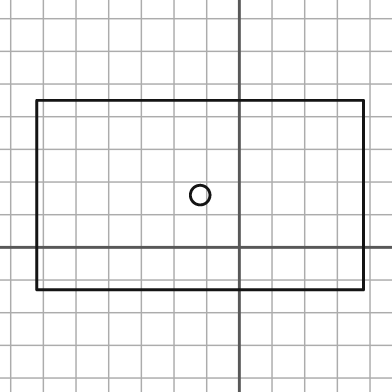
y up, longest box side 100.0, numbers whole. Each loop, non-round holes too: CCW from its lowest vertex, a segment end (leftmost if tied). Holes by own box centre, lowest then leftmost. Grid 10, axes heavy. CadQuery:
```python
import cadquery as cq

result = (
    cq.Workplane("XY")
    .moveTo(-62.0, -13.0)
    .lineTo(38.0, -13.0)
    .lineTo(38.0, 45.0)
    .lineTo(-62.0, 45.0)
    .close()
    .moveTo(-12.0, 16.0)
    .circle(3.0)
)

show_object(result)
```